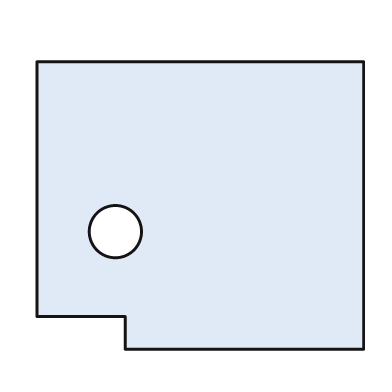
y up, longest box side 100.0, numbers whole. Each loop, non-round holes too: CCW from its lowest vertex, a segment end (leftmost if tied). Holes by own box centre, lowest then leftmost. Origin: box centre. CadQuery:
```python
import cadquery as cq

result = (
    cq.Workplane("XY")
    .moveTo(-23.0, -44.0)
    .lineTo(50.0, -44.0)
    .lineTo(50.0, 44.0)
    .lineTo(-50.0, 44.0)
    .lineTo(-50.0, -34.0)
    .lineTo(-23.0, -34.0)
    .close()
    .moveTo(-26.0, -8.0)
    .circle(8.0)
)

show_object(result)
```